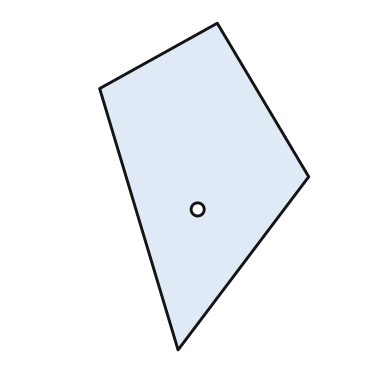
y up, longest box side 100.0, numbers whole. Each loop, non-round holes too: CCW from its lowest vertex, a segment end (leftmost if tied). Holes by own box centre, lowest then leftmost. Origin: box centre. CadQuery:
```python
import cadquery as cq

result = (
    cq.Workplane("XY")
    .moveTo(-8.0, -50.0)
    .lineTo(32.0, 3.0)
    .lineTo(4.0, 50.0)
    .lineTo(-32.0, 30.0)
    .close()
    .moveTo(-2.0, -7.0)
    .circle(2.0)
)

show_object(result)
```